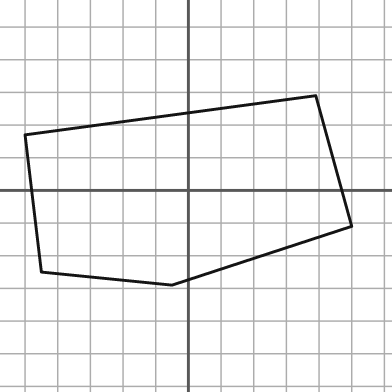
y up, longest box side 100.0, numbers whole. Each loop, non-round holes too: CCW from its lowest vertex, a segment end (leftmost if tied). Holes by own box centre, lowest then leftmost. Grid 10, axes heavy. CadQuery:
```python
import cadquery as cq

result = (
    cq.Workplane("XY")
    .moveTo(-5.0, -29.0)
    .lineTo(50.0, -11.0)
    .lineTo(39.0, 29.0)
    .lineTo(-50.0, 17.0)
    .lineTo(-45.0, -25.0)
    .close()
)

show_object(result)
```